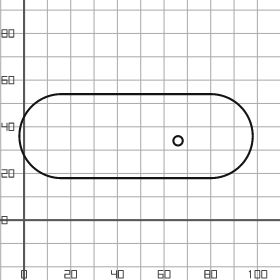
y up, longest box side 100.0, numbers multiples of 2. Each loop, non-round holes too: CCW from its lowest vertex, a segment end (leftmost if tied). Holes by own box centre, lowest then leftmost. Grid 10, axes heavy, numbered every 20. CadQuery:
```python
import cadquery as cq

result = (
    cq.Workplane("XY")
    .moveTo(16.0, 18.0)
    .lineTo(80.0, 18.0)
    .threePointArc((98.0, 36.0), (80.0, 54.0))
    .lineTo(16.0, 54.0)
    .threePointArc((-2.0, 36.0), (16.0, 18.0))
    .close()
    .moveTo(66.0, 34.0)
    .circle(2.0)
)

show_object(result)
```